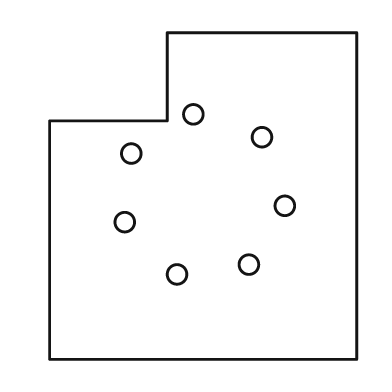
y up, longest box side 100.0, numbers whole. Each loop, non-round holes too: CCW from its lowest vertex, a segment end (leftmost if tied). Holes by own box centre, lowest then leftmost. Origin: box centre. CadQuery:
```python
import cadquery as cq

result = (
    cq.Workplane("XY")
    .moveTo(-47.0, -50.0)
    .lineTo(47.0, -50.0)
    .lineTo(47.0, 50.0)
    .lineTo(-11.0, 50.0)
    .lineTo(-11.0, 23.0)
    .lineTo(-47.0, 23.0)
    .close()
    .moveTo(-8.0, -24.0)
    .circle(3.0)
    .moveTo(14.0, -21.0)
    .circle(3.0)
    .moveTo(-24.0, -8.0)
    .circle(3.0)
    .moveTo(25.0, -3.0)
    .circle(3.0)
    .moveTo(-22.0, 13.0)
    .circle(3.0)
    .moveTo(18.0, 18.0)
    .circle(3.0)
    .moveTo(-3.0, 25.0)
    .circle(3.0)
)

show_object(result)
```